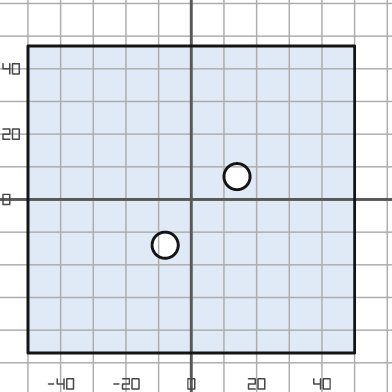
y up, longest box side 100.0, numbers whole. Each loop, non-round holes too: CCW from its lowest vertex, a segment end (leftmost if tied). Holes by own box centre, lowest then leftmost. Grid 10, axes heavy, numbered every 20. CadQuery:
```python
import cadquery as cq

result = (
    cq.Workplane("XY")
    .moveTo(-50.0, -47.0)
    .lineTo(50.0, -47.0)
    .lineTo(50.0, 47.0)
    .lineTo(-50.0, 47.0)
    .close()
    .moveTo(-8.0, -14.0)
    .circle(4.0)
    .moveTo(14.0, 7.0)
    .circle(4.0)
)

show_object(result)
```